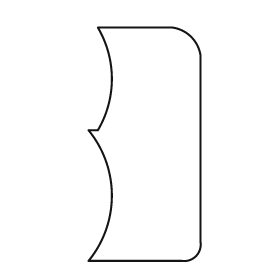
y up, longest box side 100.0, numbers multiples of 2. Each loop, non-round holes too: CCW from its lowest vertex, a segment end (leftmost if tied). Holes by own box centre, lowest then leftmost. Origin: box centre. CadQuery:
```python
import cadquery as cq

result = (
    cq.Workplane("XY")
    .moveTo(-24.0, -50.0)
    .lineTo(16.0, -50.0)
    .threePointArc((22.0, -48.0), (24.0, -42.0))
    .lineTo(24.0, 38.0)
    .threePointArc((20.0, 46.0), (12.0, 50.0))
    .lineTo(-20.0, 50.0)
    .threePointArc((-14.0, 28.0), (-20.0, 6.0))
    .lineTo(-24.0, 6.0)
    .threePointArc((-14.0, -22.0), (-24.0, -50.0))
    .close()
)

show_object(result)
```